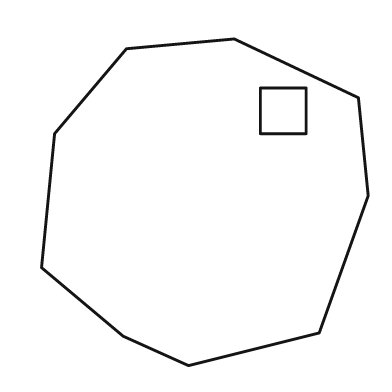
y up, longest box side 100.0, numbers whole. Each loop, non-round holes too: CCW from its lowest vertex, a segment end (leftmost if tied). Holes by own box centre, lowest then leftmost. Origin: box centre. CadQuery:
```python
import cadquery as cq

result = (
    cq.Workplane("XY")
    .moveTo(-5.0, -50.0)
    .lineTo(35.0, -40.0)
    .lineTo(50.0, 2.0)
    .lineTo(47.0, 32.0)
    .lineTo(9.0, 50.0)
    .lineTo(-24.0, 47.0)
    .lineTo(-46.0, 21.0)
    .lineTo(-50.0, -20.0)
    .lineTo(-25.0, -41.0)
    .close()
    .moveTo(17.0, 21.0)
    .lineTo(31.0, 21.0)
    .lineTo(31.0, 35.0)
    .lineTo(17.0, 35.0)
    .close()
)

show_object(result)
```